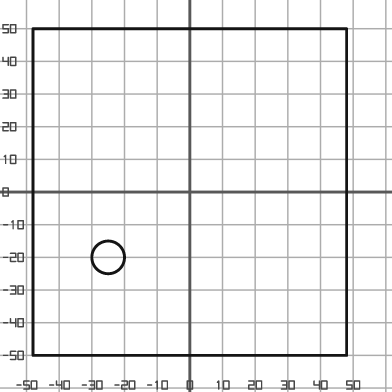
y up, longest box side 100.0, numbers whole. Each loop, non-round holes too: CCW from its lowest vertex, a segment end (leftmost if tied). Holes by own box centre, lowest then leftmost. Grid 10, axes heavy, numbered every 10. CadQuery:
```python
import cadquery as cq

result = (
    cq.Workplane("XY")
    .moveTo(-48.0, -50.0)
    .lineTo(48.0, -50.0)
    .lineTo(48.0, 50.0)
    .lineTo(-48.0, 50.0)
    .close()
    .moveTo(-25.0, -20.0)
    .circle(5.0)
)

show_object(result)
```